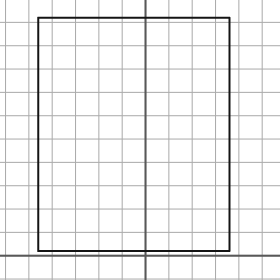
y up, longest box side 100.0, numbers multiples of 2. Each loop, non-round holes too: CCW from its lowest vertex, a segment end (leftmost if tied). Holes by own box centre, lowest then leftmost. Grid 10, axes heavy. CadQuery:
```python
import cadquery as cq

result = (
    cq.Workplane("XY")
    .moveTo(-46.0, 2.0)
    .lineTo(36.0, 2.0)
    .lineTo(36.0, 102.0)
    .lineTo(-46.0, 102.0)
    .close()
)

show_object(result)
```